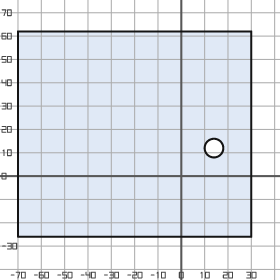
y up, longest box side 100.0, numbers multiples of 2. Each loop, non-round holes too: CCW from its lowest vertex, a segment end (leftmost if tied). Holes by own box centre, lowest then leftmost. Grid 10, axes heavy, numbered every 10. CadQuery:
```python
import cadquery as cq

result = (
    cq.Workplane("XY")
    .moveTo(-70.0, -26.0)
    .lineTo(30.0, -26.0)
    .lineTo(30.0, 62.0)
    .lineTo(-70.0, 62.0)
    .close()
    .moveTo(14.0, 12.0)
    .circle(4.0)
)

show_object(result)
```